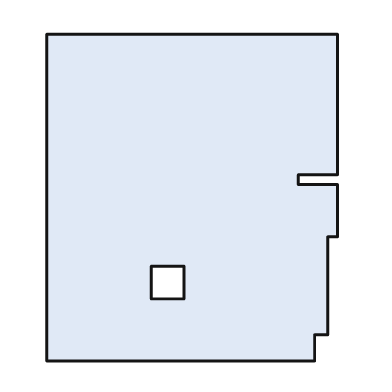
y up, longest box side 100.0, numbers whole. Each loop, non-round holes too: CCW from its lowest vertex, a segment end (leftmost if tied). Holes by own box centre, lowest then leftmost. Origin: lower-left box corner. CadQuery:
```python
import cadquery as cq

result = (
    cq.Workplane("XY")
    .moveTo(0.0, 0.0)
    .lineTo(82.0, 0.0)
    .lineTo(82.0, 8.0)
    .lineTo(86.0, 8.0)
    .lineTo(86.0, 38.0)
    .lineTo(89.0, 38.0)
    .lineTo(89.0, 54.0)
    .lineTo(77.0, 54.0)
    .lineTo(77.0, 57.0)
    .lineTo(89.0, 57.0)
    .lineTo(89.0, 100.0)
    .lineTo(0.0, 100.0)
    .close()
    .moveTo(32.0, 19.0)
    .lineTo(42.0, 19.0)
    .lineTo(42.0, 29.0)
    .lineTo(32.0, 29.0)
    .close()
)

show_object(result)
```